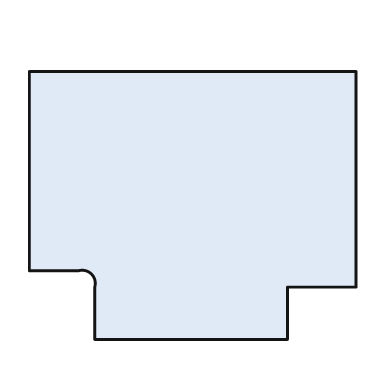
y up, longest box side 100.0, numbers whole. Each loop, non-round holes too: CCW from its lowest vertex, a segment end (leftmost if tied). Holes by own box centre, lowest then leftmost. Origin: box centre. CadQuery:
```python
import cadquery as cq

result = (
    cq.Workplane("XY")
    .moveTo(-30.0, -41.0)
    .lineTo(29.0, -41.0)
    .lineTo(29.0, -25.0)
    .lineTo(50.0, -25.0)
    .lineTo(50.0, 41.0)
    .lineTo(-50.0, 41.0)
    .lineTo(-50.0, -20.0)
    .lineTo(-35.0, -20.0)
    .threePointArc((-31.0, -21.0), (-30.0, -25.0))
    .close()
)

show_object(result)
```